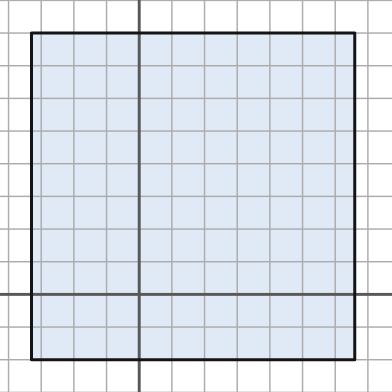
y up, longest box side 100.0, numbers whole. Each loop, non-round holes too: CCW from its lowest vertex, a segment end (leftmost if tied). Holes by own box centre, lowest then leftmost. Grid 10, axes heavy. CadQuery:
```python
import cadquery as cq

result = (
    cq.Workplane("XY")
    .moveTo(-33.0, -20.0)
    .lineTo(66.0, -20.0)
    .lineTo(66.0, 80.0)
    .lineTo(-33.0, 80.0)
    .close()
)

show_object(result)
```